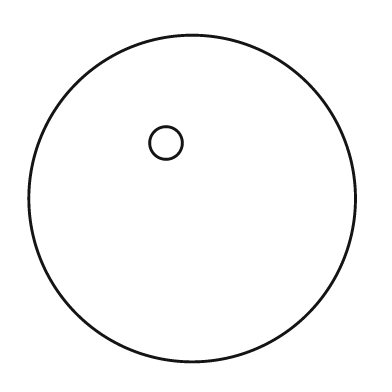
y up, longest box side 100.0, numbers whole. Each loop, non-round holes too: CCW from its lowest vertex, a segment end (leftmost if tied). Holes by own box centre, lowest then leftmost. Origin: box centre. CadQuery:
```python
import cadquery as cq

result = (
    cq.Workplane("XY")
    .moveTo(0.0, 0.0)
    .circle(50.0)
    .moveTo(-8.0, 17.0)
    .circle(5.0)
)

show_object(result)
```